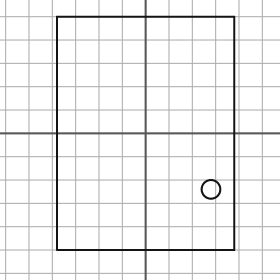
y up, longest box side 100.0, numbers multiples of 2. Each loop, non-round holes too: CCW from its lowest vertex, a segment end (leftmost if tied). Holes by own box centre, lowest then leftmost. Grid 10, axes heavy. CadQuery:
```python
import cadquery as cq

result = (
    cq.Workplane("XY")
    .moveTo(-38.0, -50.0)
    .lineTo(38.0, -50.0)
    .lineTo(38.0, 50.0)
    .lineTo(-38.0, 50.0)
    .close()
    .moveTo(28.0, -24.0)
    .circle(4.0)
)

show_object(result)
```